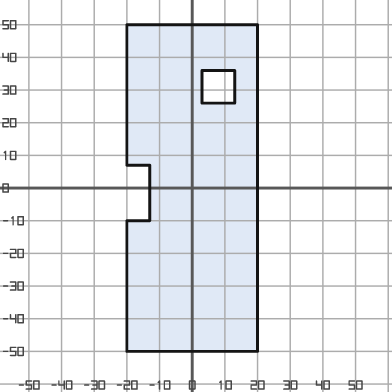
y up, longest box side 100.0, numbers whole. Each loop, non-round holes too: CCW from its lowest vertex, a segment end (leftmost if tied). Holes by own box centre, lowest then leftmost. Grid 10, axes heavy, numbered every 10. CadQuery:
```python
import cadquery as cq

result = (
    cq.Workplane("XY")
    .moveTo(-20.0, -50.0)
    .lineTo(20.0, -50.0)
    .lineTo(20.0, 50.0)
    .lineTo(-20.0, 50.0)
    .lineTo(-20.0, 7.0)
    .lineTo(-13.0, 7.0)
    .lineTo(-13.0, -10.0)
    .lineTo(-20.0, -10.0)
    .close()
    .moveTo(3.0, 26.0)
    .lineTo(13.0, 26.0)
    .lineTo(13.0, 36.0)
    .lineTo(3.0, 36.0)
    .close()
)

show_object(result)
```